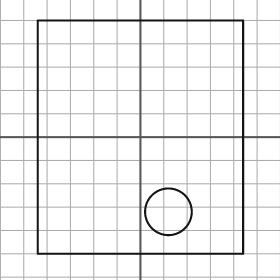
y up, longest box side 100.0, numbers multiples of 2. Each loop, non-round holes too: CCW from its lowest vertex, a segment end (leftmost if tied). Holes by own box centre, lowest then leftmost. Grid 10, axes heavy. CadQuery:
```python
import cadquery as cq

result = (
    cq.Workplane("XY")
    .moveTo(-44.0, -50.0)
    .lineTo(44.0, -50.0)
    .lineTo(44.0, 50.0)
    .lineTo(-44.0, 50.0)
    .close()
    .moveTo(12.0, -32.0)
    .circle(10.0)
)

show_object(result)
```